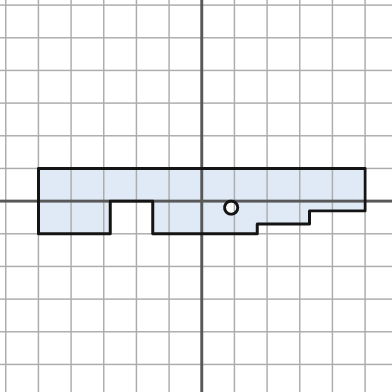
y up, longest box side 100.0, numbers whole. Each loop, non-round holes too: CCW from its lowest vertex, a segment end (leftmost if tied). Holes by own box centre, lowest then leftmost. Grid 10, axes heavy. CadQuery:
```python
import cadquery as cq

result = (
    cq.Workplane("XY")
    .moveTo(-50.0, -10.0)
    .lineTo(-28.0, -10.0)
    .lineTo(-28.0, 0.0)
    .lineTo(-15.0, 0.0)
    .lineTo(-15.0, -10.0)
    .lineTo(17.0, -10.0)
    .lineTo(17.0, -7.0)
    .lineTo(33.0, -7.0)
    .lineTo(33.0, -3.0)
    .lineTo(50.0, -3.0)
    .lineTo(50.0, 10.0)
    .lineTo(-50.0, 10.0)
    .close()
    .moveTo(9.0, -2.0)
    .circle(2.0)
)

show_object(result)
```